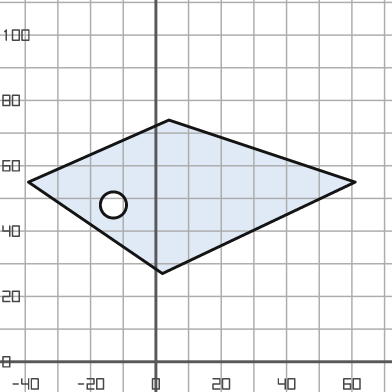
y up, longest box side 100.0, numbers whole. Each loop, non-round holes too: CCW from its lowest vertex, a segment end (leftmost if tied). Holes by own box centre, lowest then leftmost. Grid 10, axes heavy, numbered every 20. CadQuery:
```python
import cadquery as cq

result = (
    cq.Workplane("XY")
    .moveTo(2.0, 27.0)
    .lineTo(61.0, 55.0)
    .lineTo(4.0, 74.0)
    .lineTo(-39.0, 55.0)
    .close()
    .moveTo(-13.0, 48.0)
    .circle(4.0)
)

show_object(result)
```